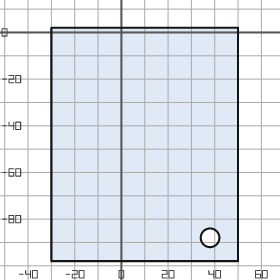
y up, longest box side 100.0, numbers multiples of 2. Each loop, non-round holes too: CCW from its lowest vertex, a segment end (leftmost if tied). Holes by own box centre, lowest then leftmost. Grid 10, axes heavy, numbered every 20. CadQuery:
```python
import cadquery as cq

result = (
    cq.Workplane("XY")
    .moveTo(-30.0, -98.0)
    .lineTo(50.0, -98.0)
    .lineTo(50.0, 2.0)
    .lineTo(-30.0, 2.0)
    .close()
    .moveTo(38.0, -88.0)
    .circle(4.0)
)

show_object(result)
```